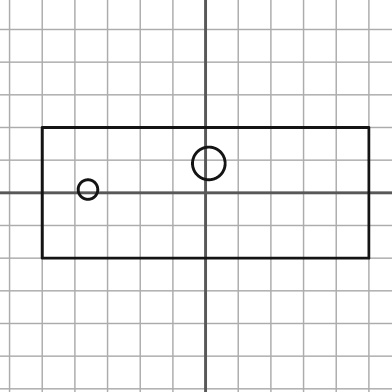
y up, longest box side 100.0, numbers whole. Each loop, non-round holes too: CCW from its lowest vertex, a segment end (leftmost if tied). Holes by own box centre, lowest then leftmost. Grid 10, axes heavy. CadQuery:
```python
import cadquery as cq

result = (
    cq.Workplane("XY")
    .moveTo(-50.0, -20.0)
    .lineTo(50.0, -20.0)
    .lineTo(50.0, 20.0)
    .lineTo(-50.0, 20.0)
    .close()
    .moveTo(-36.0, 1.0)
    .circle(3.0)
    .moveTo(1.0, 9.0)
    .circle(5.0)
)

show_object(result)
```